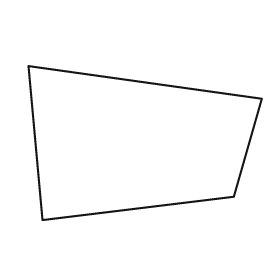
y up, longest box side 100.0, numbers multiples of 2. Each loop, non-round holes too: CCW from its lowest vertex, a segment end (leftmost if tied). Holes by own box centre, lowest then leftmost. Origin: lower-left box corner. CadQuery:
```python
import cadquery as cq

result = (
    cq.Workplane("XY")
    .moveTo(6.0, 0.0)
    .lineTo(88.0, 10.0)
    .lineTo(100.0, 52.0)
    .lineTo(0.0, 66.0)
    .close()
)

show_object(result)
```